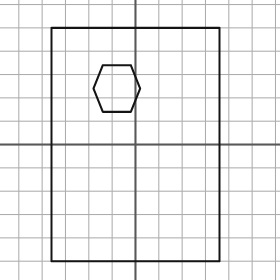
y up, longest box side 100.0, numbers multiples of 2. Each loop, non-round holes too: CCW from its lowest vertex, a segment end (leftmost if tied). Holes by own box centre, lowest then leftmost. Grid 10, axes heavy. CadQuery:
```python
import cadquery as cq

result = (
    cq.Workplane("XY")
    .moveTo(-36.0, -50.0)
    .lineTo(36.0, -50.0)
    .lineTo(36.0, 50.0)
    .lineTo(-36.0, 50.0)
    .close()
    .moveTo(-14.0, 14.0)
    .lineTo(-2.0, 14.0)
    .lineTo(2.0, 24.0)
    .lineTo(-2.0, 34.0)
    .lineTo(-14.0, 34.0)
    .lineTo(-18.0, 24.0)
    .close()
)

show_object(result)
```